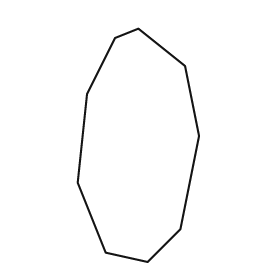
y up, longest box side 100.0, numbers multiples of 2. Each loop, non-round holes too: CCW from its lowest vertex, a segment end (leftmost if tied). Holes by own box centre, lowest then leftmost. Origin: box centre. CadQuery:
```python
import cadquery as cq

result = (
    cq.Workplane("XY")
    .moveTo(4.0, -50.0)
    .lineTo(18.0, -36.0)
    .lineTo(26.0, 4.0)
    .lineTo(20.0, 34.0)
    .lineTo(0.0, 50.0)
    .lineTo(-10.0, 46.0)
    .lineTo(-22.0, 22.0)
    .lineTo(-26.0, -16.0)
    .lineTo(-14.0, -46.0)
    .close()
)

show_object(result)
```